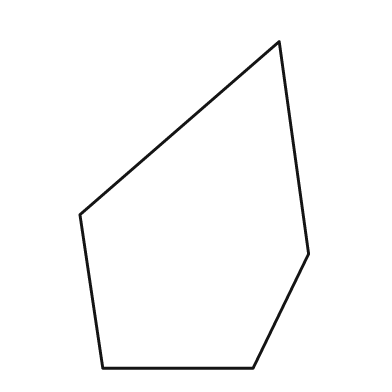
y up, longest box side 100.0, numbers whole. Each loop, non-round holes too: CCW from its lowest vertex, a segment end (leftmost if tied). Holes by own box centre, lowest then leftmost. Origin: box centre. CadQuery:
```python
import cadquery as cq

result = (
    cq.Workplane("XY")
    .moveTo(-28.0, -50.0)
    .lineTo(18.0, -50.0)
    .lineTo(35.0, -15.0)
    .lineTo(26.0, 50.0)
    .lineTo(-35.0, -3.0)
    .close()
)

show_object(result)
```